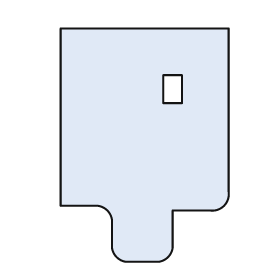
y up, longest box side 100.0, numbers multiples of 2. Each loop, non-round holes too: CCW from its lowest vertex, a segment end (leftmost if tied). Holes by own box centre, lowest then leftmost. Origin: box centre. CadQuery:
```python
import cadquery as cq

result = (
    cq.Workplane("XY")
    .moveTo(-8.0, -50.0)
    .lineTo(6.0, -50.0)
    .threePointArc((10.0, -48.0), (12.0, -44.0))
    .lineTo(12.0, -28.0)
    .lineTo(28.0, -28.0)
    .threePointArc((34.0, -26.0), (36.0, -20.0))
    .lineTo(36.0, 50.0)
    .lineTo(-36.0, 50.0)
    .lineTo(-36.0, -26.0)
    .lineTo(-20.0, -26.0)
    .threePointArc((-16.0, -28.0), (-14.0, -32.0))
    .lineTo(-14.0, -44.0)
    .threePointArc((-12.0, -48.0), (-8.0, -50.0))
    .close()
    .moveTo(8.0, 18.0)
    .lineTo(16.0, 18.0)
    .lineTo(16.0, 30.0)
    .lineTo(8.0, 30.0)
    .close()
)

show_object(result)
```